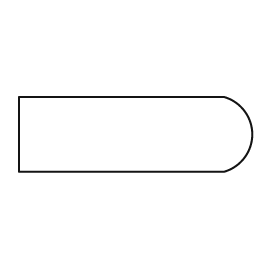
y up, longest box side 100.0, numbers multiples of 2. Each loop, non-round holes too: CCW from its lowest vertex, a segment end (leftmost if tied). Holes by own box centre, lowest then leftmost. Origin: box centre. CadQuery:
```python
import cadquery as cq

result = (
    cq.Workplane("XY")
    .moveTo(-50.0, -16.0)
    .lineTo(38.0, -16.0)
    .threePointArc((50.0, 0.0), (38.0, 16.0))
    .lineTo(-50.0, 16.0)
    .close()
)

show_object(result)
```